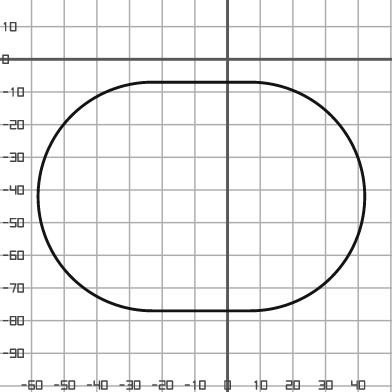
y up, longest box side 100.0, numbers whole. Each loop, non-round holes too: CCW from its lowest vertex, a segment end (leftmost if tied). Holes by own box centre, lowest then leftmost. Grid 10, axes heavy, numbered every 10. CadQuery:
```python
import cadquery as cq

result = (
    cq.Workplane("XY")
    .moveTo(-23.0, -77.0)
    .lineTo(7.0, -77.0)
    .threePointArc((42.0, -42.0), (7.0, -7.0))
    .lineTo(-23.0, -7.0)
    .threePointArc((-58.0, -42.0), (-23.0, -77.0))
    .close()
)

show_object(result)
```